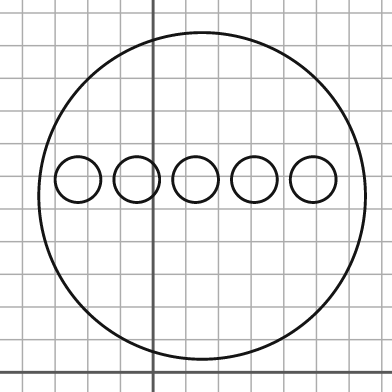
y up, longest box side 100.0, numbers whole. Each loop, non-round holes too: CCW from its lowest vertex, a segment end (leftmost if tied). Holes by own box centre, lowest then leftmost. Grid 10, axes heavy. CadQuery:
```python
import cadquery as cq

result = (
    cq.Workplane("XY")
    .moveTo(15.0, 54.0)
    .circle(50.0)
    .moveTo(-23.0, 59.0)
    .circle(7.0)
    .moveTo(-5.0, 59.0)
    .circle(7.0)
    .moveTo(13.0, 59.0)
    .circle(7.0)
    .moveTo(31.0, 59.0)
    .circle(7.0)
    .moveTo(49.0, 59.0)
    .circle(7.0)
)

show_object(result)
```